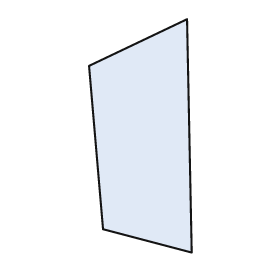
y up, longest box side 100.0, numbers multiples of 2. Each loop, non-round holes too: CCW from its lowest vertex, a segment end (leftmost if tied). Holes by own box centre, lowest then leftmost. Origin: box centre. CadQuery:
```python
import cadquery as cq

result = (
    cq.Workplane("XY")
    .moveTo(22.0, -50.0)
    .lineTo(20.0, 50.0)
    .lineTo(-22.0, 30.0)
    .lineTo(-16.0, -40.0)
    .close()
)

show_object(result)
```